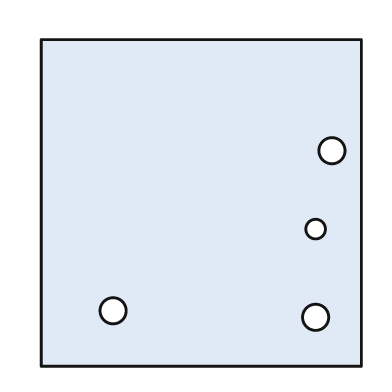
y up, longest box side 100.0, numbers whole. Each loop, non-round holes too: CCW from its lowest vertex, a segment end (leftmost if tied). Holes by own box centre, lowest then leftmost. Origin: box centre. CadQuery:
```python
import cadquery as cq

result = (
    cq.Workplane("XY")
    .moveTo(-49.0, -50.0)
    .lineTo(49.0, -50.0)
    .lineTo(49.0, 50.0)
    .lineTo(-49.0, 50.0)
    .close()
    .moveTo(35.0, -35.0)
    .circle(4.0)
    .moveTo(-27.0, -33.0)
    .circle(4.0)
    .moveTo(35.0, -8.0)
    .circle(3.0)
    .moveTo(40.0, 16.0)
    .circle(4.0)
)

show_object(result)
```